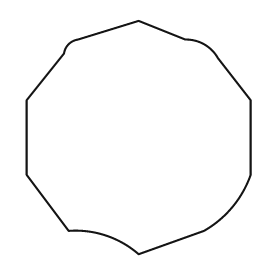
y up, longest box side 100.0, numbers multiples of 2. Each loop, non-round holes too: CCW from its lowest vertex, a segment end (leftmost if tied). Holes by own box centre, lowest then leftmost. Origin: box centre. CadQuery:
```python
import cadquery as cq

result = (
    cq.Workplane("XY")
    .moveTo(0.0, -50.0)
    .lineTo(28.0, -40.0)
    .threePointArc((40.0, -30.0), (48.0, -16.0))
    .lineTo(48.0, 16.0)
    .lineTo(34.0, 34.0)
    .threePointArc((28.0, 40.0), (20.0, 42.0))
    .lineTo(0.0, 50.0)
    .lineTo(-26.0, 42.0)
    .threePointArc((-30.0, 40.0), (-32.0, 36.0))
    .lineTo(-48.0, 16.0)
    .lineTo(-48.0, -16.0)
    .lineTo(-30.0, -40.0)
    .threePointArc((-14.0, -42.0), (0.0, -50.0))
    .close()
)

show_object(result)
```